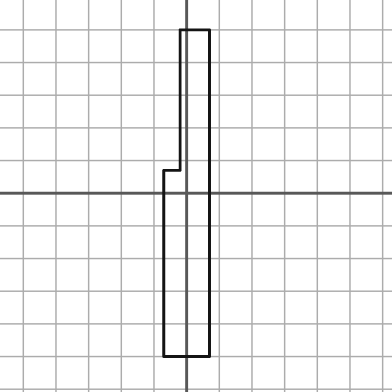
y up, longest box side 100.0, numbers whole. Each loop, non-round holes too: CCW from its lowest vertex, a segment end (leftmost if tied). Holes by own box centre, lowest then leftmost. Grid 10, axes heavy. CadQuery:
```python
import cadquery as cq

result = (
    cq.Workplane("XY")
    .moveTo(-7.0, -50.0)
    .lineTo(7.0, -50.0)
    .lineTo(7.0, 50.0)
    .lineTo(-2.0, 50.0)
    .lineTo(-2.0, 7.0)
    .lineTo(-7.0, 7.0)
    .close()
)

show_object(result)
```